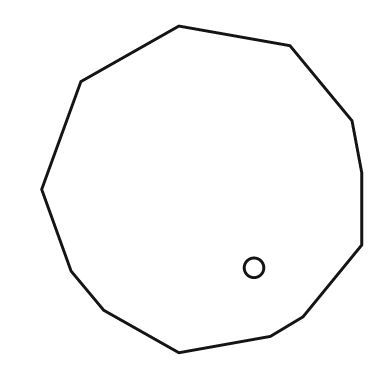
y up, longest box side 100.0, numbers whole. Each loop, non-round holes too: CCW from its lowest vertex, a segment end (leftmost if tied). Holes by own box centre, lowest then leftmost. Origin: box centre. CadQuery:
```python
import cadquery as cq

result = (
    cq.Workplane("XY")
    .moveTo(-7.0, -50.0)
    .lineTo(21.0, -45.0)
    .lineTo(31.0, -39.0)
    .lineTo(49.0, -17.0)
    .lineTo(49.0, 5.0)
    .lineTo(46.0, 21.0)
    .lineTo(27.0, 44.0)
    .lineTo(-7.0, 50.0)
    .lineTo(-37.0, 33.0)
    .lineTo(-49.0, 0.0)
    .lineTo(-40.0, -25.0)
    .lineTo(-30.0, -37.0)
    .close()
    .moveTo(16.0, -24.0)
    .circle(3.0)
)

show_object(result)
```